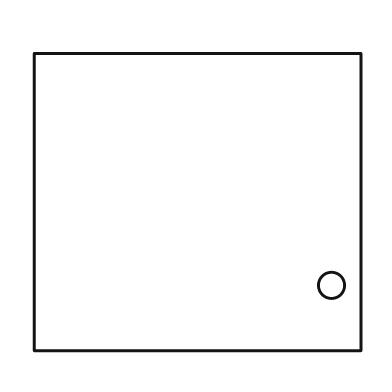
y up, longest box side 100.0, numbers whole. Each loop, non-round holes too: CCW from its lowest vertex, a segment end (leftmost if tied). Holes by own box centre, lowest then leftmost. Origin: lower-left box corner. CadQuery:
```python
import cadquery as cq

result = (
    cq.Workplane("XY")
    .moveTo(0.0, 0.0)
    .lineTo(100.0, 0.0)
    .lineTo(100.0, 91.0)
    .lineTo(0.0, 91.0)
    .close()
    .moveTo(91.0, 20.0)
    .circle(4.0)
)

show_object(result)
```